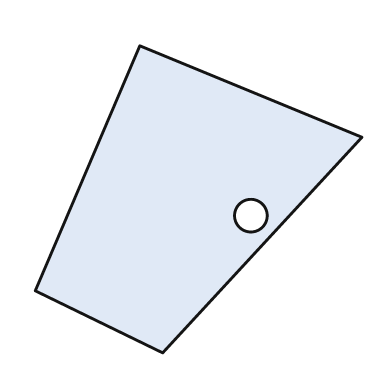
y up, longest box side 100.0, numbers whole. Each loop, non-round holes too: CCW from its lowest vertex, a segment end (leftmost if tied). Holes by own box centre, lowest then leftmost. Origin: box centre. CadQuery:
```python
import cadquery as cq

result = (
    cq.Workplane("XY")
    .moveTo(-11.0, -47.0)
    .lineTo(50.0, 19.0)
    .lineTo(-18.0, 47.0)
    .lineTo(-50.0, -28.0)
    .close()
    .moveTo(16.0, -5.0)
    .circle(5.0)
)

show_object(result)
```